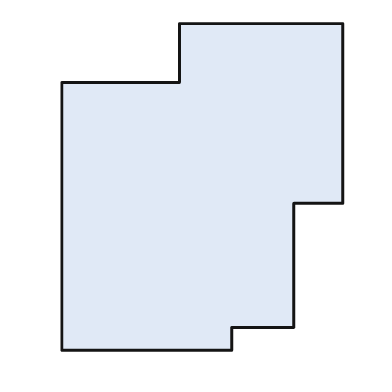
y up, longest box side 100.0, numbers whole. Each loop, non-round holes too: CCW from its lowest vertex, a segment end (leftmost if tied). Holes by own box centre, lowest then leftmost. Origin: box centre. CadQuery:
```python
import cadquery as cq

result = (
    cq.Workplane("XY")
    .moveTo(-43.0, -50.0)
    .lineTo(9.0, -50.0)
    .lineTo(9.0, -43.0)
    .lineTo(28.0, -43.0)
    .lineTo(28.0, -5.0)
    .lineTo(43.0, -5.0)
    .lineTo(43.0, 50.0)
    .lineTo(-7.0, 50.0)
    .lineTo(-7.0, 32.0)
    .lineTo(-43.0, 32.0)
    .close()
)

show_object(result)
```